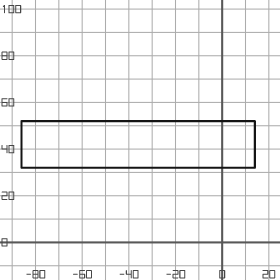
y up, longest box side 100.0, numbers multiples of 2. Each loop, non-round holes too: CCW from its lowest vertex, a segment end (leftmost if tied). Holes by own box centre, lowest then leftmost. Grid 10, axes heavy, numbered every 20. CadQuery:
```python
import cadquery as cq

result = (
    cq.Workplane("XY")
    .moveTo(-86.0, 32.0)
    .lineTo(14.0, 32.0)
    .lineTo(14.0, 52.0)
    .lineTo(-86.0, 52.0)
    .close()
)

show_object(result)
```